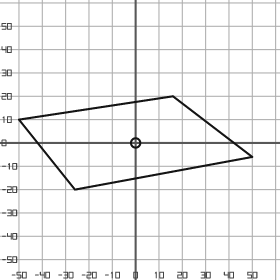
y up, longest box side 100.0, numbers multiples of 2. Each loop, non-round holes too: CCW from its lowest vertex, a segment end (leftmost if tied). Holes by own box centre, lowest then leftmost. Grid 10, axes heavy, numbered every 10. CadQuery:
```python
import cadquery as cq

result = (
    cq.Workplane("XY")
    .moveTo(-26.0, -20.0)
    .lineTo(50.0, -6.0)
    .lineTo(16.0, 20.0)
    .lineTo(-50.0, 10.0)
    .close()
    .moveTo(0.0, 0.0)
    .circle(2.0)
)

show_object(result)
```